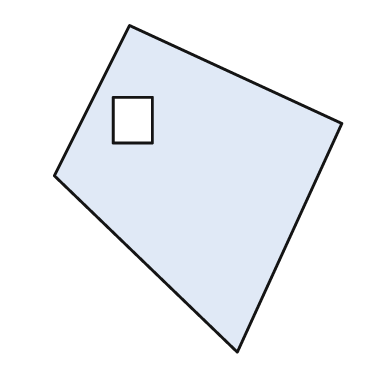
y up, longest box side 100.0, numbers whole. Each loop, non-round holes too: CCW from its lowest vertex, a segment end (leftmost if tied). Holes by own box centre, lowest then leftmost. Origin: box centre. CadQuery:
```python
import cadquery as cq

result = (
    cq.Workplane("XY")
    .moveTo(12.0, -50.0)
    .lineTo(44.0, 20.0)
    .lineTo(-21.0, 50.0)
    .lineTo(-44.0, 4.0)
    .close()
    .moveTo(-26.0, 14.0)
    .lineTo(-14.0, 14.0)
    .lineTo(-14.0, 28.0)
    .lineTo(-26.0, 28.0)
    .close()
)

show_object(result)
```